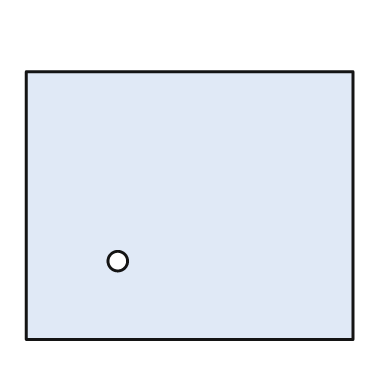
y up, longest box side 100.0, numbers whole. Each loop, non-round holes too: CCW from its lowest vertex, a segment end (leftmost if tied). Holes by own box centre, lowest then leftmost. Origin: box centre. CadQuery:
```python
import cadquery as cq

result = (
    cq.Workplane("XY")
    .moveTo(-50.0, -41.0)
    .lineTo(50.0, -41.0)
    .lineTo(50.0, 41.0)
    .lineTo(-50.0, 41.0)
    .close()
    .moveTo(-22.0, -17.0)
    .circle(3.0)
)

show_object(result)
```